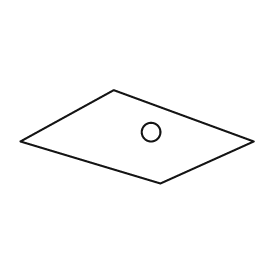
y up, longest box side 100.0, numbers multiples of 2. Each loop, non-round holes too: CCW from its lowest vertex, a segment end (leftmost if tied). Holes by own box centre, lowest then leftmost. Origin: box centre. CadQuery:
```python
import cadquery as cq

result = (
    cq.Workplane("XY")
    .moveTo(10.0, -20.0)
    .lineTo(50.0, -2.0)
    .lineTo(-10.0, 20.0)
    .lineTo(-50.0, -2.0)
    .close()
    .moveTo(6.0, 2.0)
    .circle(4.0)
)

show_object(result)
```